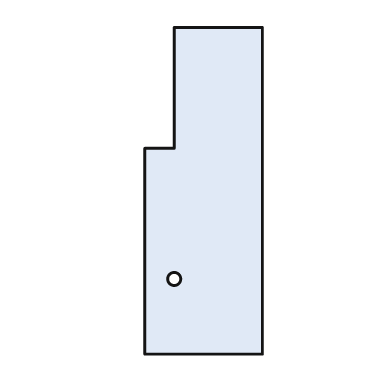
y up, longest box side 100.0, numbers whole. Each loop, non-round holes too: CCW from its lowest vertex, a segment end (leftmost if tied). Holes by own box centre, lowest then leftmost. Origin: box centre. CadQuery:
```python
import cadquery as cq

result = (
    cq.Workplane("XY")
    .moveTo(-18.0, -50.0)
    .lineTo(18.0, -50.0)
    .lineTo(18.0, 50.0)
    .lineTo(-9.0, 50.0)
    .lineTo(-9.0, 13.0)
    .lineTo(-18.0, 13.0)
    .close()
    .moveTo(-9.0, -27.0)
    .circle(2.0)
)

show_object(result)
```